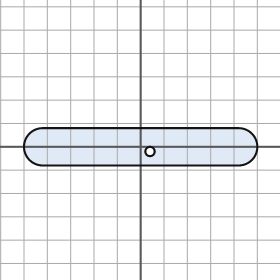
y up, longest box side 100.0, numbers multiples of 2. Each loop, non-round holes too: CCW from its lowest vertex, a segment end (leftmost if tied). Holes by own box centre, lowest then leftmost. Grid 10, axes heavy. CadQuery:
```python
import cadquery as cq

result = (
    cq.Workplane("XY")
    .moveTo(-42.0, -8.0)
    .lineTo(42.0, -8.0)
    .threePointArc((50.0, 0.0), (42.0, 8.0))
    .lineTo(-42.0, 8.0)
    .threePointArc((-50.0, 0.0), (-42.0, -8.0))
    .close()
    .moveTo(4.0, -2.0)
    .circle(2.0)
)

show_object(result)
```